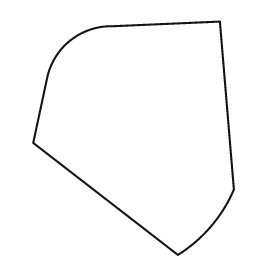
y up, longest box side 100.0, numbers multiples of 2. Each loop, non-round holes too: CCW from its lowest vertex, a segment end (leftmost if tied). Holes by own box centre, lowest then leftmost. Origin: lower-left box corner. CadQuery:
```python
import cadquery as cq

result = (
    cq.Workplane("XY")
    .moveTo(62.0, 0.0)
    .threePointArc((76.0, 12.0), (86.0, 28.0))
    .lineTo(80.0, 100.0)
    .lineTo(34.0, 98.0)
    .threePointArc((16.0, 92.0), (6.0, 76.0))
    .lineTo(0.0, 48.0)
    .close()
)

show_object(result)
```